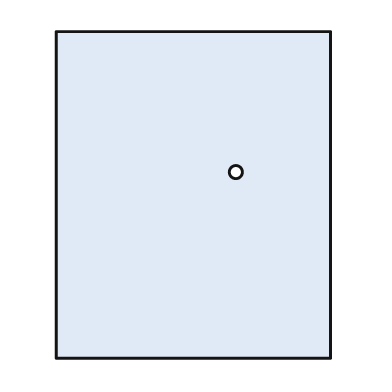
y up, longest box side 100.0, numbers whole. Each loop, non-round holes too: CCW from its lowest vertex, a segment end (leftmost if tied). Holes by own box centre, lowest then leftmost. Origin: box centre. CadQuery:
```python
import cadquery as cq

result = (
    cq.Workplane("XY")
    .moveTo(-42.0, -50.0)
    .lineTo(42.0, -50.0)
    .lineTo(42.0, 50.0)
    .lineTo(-42.0, 50.0)
    .close()
    .moveTo(13.0, 7.0)
    .circle(2.0)
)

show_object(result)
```